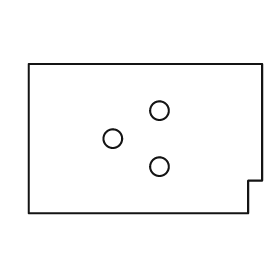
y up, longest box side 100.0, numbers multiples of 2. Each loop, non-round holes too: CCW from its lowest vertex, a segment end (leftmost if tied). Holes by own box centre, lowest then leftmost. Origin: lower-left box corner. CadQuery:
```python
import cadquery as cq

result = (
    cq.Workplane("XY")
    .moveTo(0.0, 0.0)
    .lineTo(94.0, 0.0)
    .lineTo(94.0, 14.0)
    .lineTo(100.0, 14.0)
    .lineTo(100.0, 64.0)
    .lineTo(0.0, 64.0)
    .close()
    .moveTo(56.0, 20.0)
    .circle(4.0)
    .moveTo(36.0, 32.0)
    .circle(4.0)
    .moveTo(56.0, 44.0)
    .circle(4.0)
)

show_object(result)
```